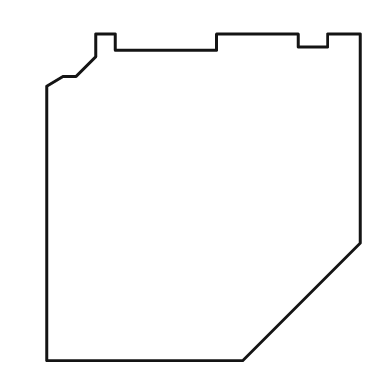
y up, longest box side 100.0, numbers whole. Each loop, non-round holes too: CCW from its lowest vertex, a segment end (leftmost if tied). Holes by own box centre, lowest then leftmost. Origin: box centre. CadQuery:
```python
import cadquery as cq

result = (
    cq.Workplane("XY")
    .moveTo(-48.0, -50.0)
    .lineTo(12.0, -50.0)
    .lineTo(48.0, -14.0)
    .lineTo(48.0, 50.0)
    .lineTo(38.0, 50.0)
    .lineTo(38.0, 46.0)
    .lineTo(29.0, 46.0)
    .lineTo(29.0, 50.0)
    .lineTo(4.0, 50.0)
    .lineTo(4.0, 45.0)
    .lineTo(-27.0, 45.0)
    .lineTo(-27.0, 50.0)
    .lineTo(-33.0, 50.0)
    .lineTo(-33.0, 43.0)
    .lineTo(-39.0, 37.0)
    .lineTo(-43.0, 37.0)
    .lineTo(-48.0, 34.0)
    .close()
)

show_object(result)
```